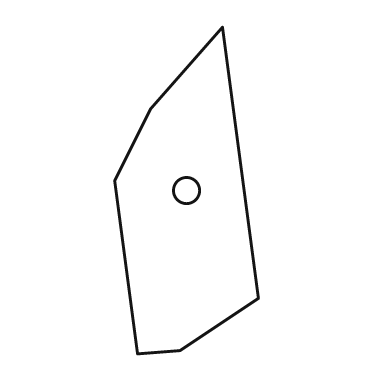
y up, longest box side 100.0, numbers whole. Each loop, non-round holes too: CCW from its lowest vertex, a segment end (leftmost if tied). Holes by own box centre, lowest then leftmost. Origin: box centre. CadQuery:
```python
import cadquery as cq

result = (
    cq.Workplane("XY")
    .moveTo(-15.0, -50.0)
    .lineTo(-2.0, -49.0)
    .lineTo(22.0, -33.0)
    .lineTo(11.0, 50.0)
    .lineTo(-11.0, 25.0)
    .lineTo(-22.0, 3.0)
    .close()
    .moveTo(0.0, 0.0)
    .circle(4.0)
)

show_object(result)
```